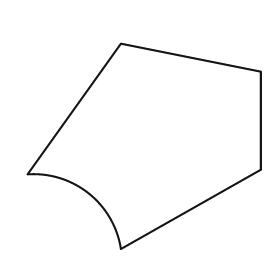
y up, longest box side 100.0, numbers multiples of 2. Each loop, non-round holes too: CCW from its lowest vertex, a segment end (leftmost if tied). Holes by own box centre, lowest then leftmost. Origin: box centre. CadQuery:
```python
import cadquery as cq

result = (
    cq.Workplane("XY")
    .moveTo(-10.0, -44.0)
    .lineTo(50.0, -10.0)
    .lineTo(50.0, 32.0)
    .lineTo(-10.0, 44.0)
    .lineTo(-50.0, -12.0)
    .threePointArc((-24.0, -20.0), (-10.0, -44.0))
    .close()
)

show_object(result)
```